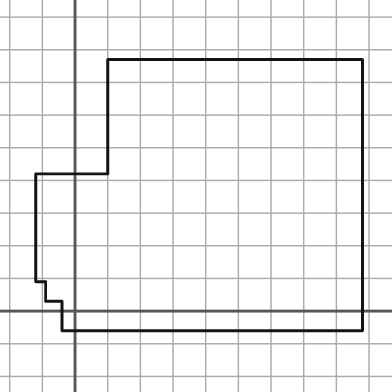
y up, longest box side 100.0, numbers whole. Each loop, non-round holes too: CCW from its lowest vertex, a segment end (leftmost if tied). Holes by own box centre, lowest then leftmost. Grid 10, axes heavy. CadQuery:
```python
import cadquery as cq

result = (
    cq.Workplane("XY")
    .moveTo(-4.0, -6.0)
    .lineTo(88.0, -6.0)
    .lineTo(88.0, 77.0)
    .lineTo(10.0, 77.0)
    .lineTo(10.0, 42.0)
    .lineTo(-12.0, 42.0)
    .lineTo(-12.0, 9.0)
    .lineTo(-9.0, 9.0)
    .lineTo(-9.0, 3.0)
    .lineTo(-4.0, 3.0)
    .close()
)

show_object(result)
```